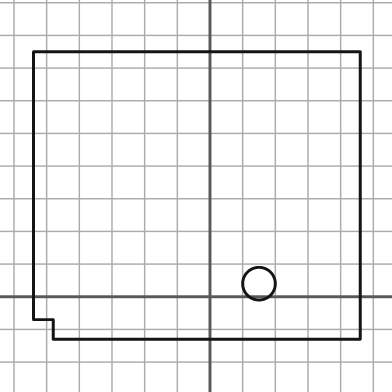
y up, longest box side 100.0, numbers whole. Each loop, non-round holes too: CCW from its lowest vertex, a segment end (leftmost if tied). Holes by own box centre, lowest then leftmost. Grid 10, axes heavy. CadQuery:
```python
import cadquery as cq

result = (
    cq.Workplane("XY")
    .moveTo(-48.0, -13.0)
    .lineTo(46.0, -13.0)
    .lineTo(46.0, 75.0)
    .lineTo(-54.0, 75.0)
    .lineTo(-54.0, -7.0)
    .lineTo(-48.0, -7.0)
    .close()
    .moveTo(15.0, 4.0)
    .circle(5.0)
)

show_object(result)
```